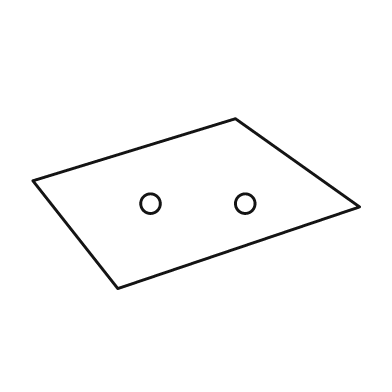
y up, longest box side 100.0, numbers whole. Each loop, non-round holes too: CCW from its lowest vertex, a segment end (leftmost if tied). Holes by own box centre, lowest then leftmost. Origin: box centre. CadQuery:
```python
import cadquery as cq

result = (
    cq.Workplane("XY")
    .moveTo(-24.0, -26.0)
    .lineTo(50.0, -1.0)
    .lineTo(12.0, 26.0)
    .lineTo(-50.0, 7.0)
    .close()
    .moveTo(-14.0, 0.0)
    .circle(3.0)
    .moveTo(15.0, 0.0)
    .circle(3.0)
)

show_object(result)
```